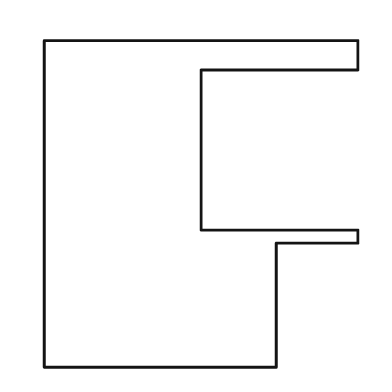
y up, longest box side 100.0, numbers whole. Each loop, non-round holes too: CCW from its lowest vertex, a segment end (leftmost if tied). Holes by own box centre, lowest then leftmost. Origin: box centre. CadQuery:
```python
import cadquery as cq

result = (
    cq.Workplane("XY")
    .moveTo(-48.0, -50.0)
    .lineTo(23.0, -50.0)
    .lineTo(23.0, -12.0)
    .lineTo(48.0, -12.0)
    .lineTo(48.0, -8.0)
    .lineTo(0.0, -8.0)
    .lineTo(0.0, 41.0)
    .lineTo(48.0, 41.0)
    .lineTo(48.0, 50.0)
    .lineTo(-48.0, 50.0)
    .close()
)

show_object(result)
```